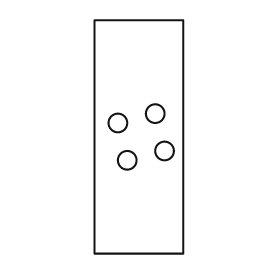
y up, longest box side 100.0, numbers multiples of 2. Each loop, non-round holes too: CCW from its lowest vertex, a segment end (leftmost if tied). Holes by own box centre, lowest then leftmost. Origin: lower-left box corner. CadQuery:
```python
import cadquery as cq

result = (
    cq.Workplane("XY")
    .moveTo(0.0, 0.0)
    .lineTo(38.0, 0.0)
    .lineTo(38.0, 100.0)
    .lineTo(0.0, 100.0)
    .close()
    .moveTo(14.0, 40.0)
    .circle(4.0)
    .moveTo(30.0, 44.0)
    .circle(4.0)
    .moveTo(10.0, 56.0)
    .circle(4.0)
    .moveTo(26.0, 60.0)
    .circle(4.0)
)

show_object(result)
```